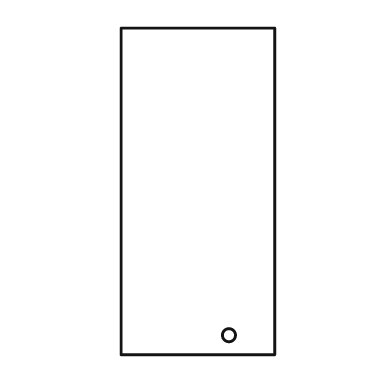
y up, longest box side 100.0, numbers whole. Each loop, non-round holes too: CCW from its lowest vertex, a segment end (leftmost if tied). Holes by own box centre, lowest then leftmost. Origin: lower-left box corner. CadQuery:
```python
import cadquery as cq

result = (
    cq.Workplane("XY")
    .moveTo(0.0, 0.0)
    .lineTo(47.0, 0.0)
    .lineTo(47.0, 100.0)
    .lineTo(0.0, 100.0)
    .close()
    .moveTo(33.0, 6.0)
    .circle(2.0)
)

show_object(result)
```